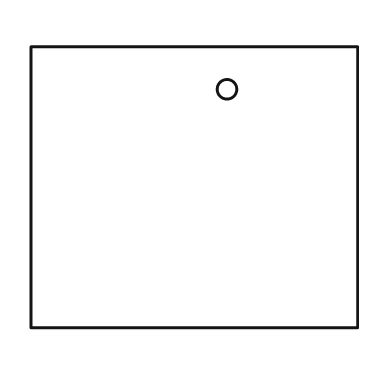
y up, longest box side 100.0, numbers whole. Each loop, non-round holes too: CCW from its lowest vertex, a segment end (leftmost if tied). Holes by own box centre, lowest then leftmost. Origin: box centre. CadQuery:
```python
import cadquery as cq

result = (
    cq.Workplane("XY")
    .moveTo(-50.0, -43.0)
    .lineTo(50.0, -43.0)
    .lineTo(50.0, 43.0)
    .lineTo(-50.0, 43.0)
    .close()
    .moveTo(10.0, 30.0)
    .circle(3.0)
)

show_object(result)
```